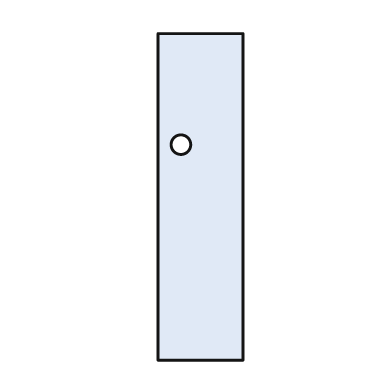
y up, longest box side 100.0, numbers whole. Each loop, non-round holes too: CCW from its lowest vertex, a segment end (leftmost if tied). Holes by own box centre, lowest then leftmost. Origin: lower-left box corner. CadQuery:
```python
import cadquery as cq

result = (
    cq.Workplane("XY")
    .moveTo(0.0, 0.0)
    .lineTo(26.0, 0.0)
    .lineTo(26.0, 100.0)
    .lineTo(0.0, 100.0)
    .close()
    .moveTo(7.0, 66.0)
    .circle(3.0)
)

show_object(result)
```